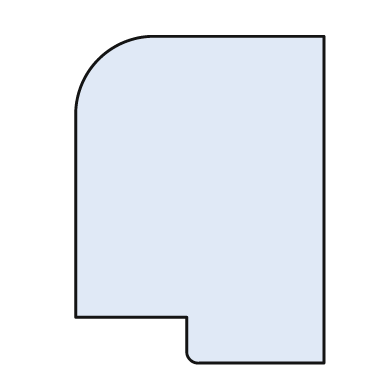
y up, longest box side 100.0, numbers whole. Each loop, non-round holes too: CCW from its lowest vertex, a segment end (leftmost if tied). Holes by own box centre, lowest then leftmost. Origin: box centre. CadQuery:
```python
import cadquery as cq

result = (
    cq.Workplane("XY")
    .moveTo(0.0, -50.0)
    .lineTo(38.0, -50.0)
    .lineTo(38.0, 50.0)
    .lineTo(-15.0, 50.0)
    .threePointArc((-31.0, 43.0), (-38.0, 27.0))
    .lineTo(-38.0, -36.0)
    .lineTo(-4.0, -36.0)
    .lineTo(-4.0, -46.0)
    .threePointArc((-3.0, -49.0), (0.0, -50.0))
    .close()
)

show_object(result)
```